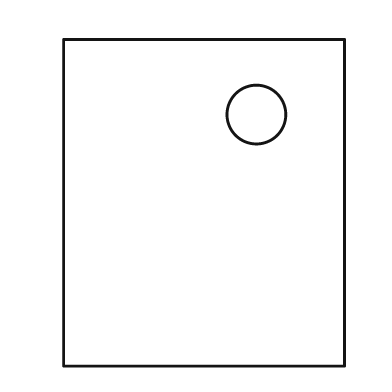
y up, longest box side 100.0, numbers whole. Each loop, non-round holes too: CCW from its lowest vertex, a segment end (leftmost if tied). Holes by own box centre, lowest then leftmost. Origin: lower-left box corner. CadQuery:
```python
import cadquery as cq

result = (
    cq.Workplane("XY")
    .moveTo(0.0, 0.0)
    .lineTo(86.0, 0.0)
    .lineTo(86.0, 100.0)
    .lineTo(0.0, 100.0)
    .close()
    .moveTo(59.0, 77.0)
    .circle(9.0)
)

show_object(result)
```